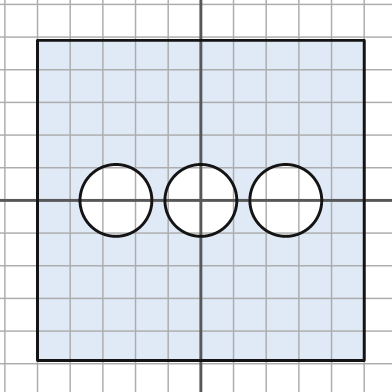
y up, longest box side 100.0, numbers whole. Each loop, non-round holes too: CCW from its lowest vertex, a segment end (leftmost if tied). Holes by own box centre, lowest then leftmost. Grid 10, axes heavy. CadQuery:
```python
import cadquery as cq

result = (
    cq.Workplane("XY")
    .moveTo(-50.0, -49.0)
    .lineTo(50.0, -49.0)
    .lineTo(50.0, 49.0)
    .lineTo(-50.0, 49.0)
    .close()
    .moveTo(-26.0, 0.0)
    .circle(11.0)
    .moveTo(0.0, 0.0)
    .circle(11.0)
    .moveTo(26.0, 0.0)
    .circle(11.0)
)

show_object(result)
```